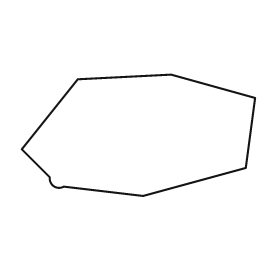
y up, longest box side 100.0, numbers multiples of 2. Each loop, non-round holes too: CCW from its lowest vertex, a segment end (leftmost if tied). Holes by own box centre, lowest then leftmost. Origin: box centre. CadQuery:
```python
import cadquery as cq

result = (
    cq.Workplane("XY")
    .moveTo(2.0, -26.0)
    .lineTo(46.0, -14.0)
    .lineTo(50.0, 16.0)
    .lineTo(14.0, 26.0)
    .lineTo(-26.0, 24.0)
    .lineTo(-50.0, -6.0)
    .lineTo(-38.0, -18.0)
    .threePointArc((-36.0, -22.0), (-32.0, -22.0))
    .close()
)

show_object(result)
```